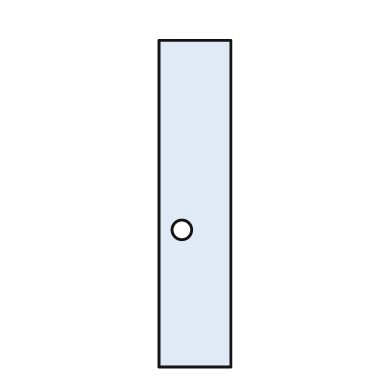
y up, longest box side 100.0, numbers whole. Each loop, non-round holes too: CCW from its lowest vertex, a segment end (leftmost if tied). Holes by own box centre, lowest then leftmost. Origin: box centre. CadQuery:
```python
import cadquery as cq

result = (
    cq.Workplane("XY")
    .moveTo(-11.0, -50.0)
    .lineTo(11.0, -50.0)
    .lineTo(11.0, 50.0)
    .lineTo(-11.0, 50.0)
    .close()
    .moveTo(-4.0, -8.0)
    .circle(3.0)
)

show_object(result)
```